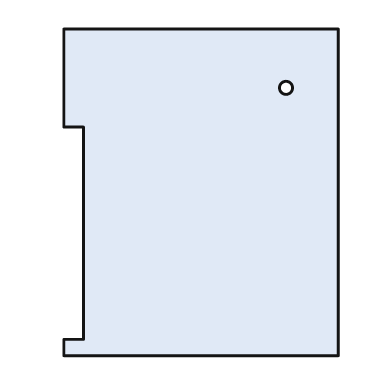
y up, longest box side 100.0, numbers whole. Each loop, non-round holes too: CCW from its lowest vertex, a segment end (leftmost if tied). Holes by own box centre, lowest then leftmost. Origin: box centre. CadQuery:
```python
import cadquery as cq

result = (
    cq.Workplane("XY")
    .moveTo(-42.0, -50.0)
    .lineTo(42.0, -50.0)
    .lineTo(42.0, 50.0)
    .lineTo(-42.0, 50.0)
    .lineTo(-42.0, 20.0)
    .lineTo(-36.0, 20.0)
    .lineTo(-36.0, -45.0)
    .lineTo(-42.0, -45.0)
    .close()
    .moveTo(26.0, 32.0)
    .circle(2.0)
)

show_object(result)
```